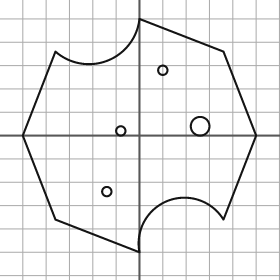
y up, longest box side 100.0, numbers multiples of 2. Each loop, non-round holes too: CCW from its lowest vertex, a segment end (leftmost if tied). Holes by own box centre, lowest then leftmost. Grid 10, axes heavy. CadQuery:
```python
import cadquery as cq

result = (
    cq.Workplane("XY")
    .moveTo(0.0, -50.0)
    .threePointArc((12.0, -28.0), (36.0, -36.0))
    .lineTo(50.0, 0.0)
    .lineTo(36.0, 36.0)
    .lineTo(0.0, 50.0)
    .threePointArc((-14.0, 32.0), (-36.0, 36.0))
    .lineTo(-50.0, 0.0)
    .lineTo(-36.0, -36.0)
    .close()
    .moveTo(-14.0, -24.0)
    .circle(2.0)
    .moveTo(-8.0, 2.0)
    .circle(2.0)
    .moveTo(26.0, 4.0)
    .circle(4.0)
    .moveTo(10.0, 28.0)
    .circle(2.0)
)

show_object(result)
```